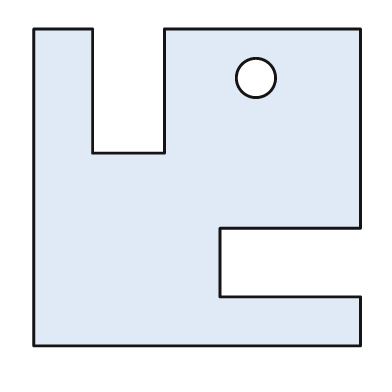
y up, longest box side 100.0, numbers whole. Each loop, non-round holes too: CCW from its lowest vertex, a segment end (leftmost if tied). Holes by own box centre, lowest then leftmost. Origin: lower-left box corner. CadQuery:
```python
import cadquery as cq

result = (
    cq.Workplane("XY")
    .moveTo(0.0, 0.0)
    .lineTo(100.0, 0.0)
    .lineTo(100.0, 15.0)
    .lineTo(57.0, 15.0)
    .lineTo(57.0, 36.0)
    .lineTo(100.0, 36.0)
    .lineTo(100.0, 97.0)
    .lineTo(40.0, 97.0)
    .lineTo(40.0, 59.0)
    .lineTo(18.0, 59.0)
    .lineTo(18.0, 97.0)
    .lineTo(0.0, 97.0)
    .close()
    .moveTo(68.0, 82.0)
    .circle(6.0)
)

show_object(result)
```